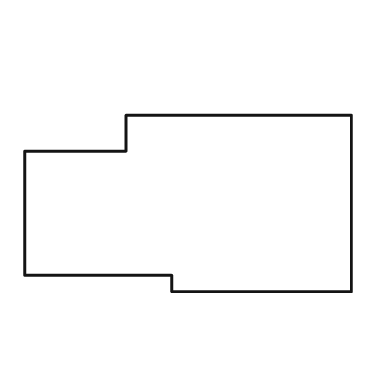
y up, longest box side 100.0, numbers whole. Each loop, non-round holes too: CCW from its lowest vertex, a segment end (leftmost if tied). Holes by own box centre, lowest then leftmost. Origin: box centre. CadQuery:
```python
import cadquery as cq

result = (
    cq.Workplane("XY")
    .moveTo(-5.0, -27.0)
    .lineTo(50.0, -27.0)
    .lineTo(50.0, 27.0)
    .lineTo(-19.0, 27.0)
    .lineTo(-19.0, 16.0)
    .lineTo(-50.0, 16.0)
    .lineTo(-50.0, -22.0)
    .lineTo(-5.0, -22.0)
    .close()
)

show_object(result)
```